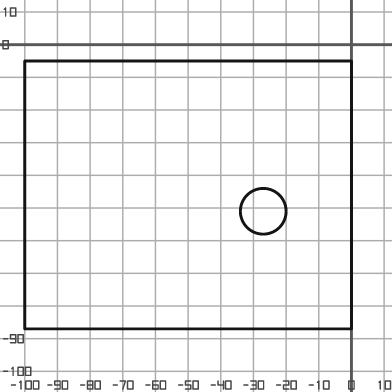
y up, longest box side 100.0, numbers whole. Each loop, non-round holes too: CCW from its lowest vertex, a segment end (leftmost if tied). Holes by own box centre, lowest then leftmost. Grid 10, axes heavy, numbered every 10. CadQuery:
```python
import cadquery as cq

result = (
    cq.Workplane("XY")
    .moveTo(-100.0, -87.0)
    .lineTo(0.0, -87.0)
    .lineTo(0.0, -5.0)
    .lineTo(-100.0, -5.0)
    .close()
    .moveTo(-27.0, -51.0)
    .circle(7.0)
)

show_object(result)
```